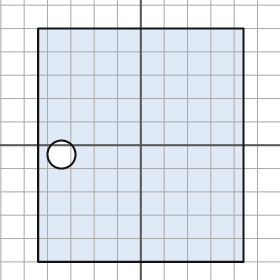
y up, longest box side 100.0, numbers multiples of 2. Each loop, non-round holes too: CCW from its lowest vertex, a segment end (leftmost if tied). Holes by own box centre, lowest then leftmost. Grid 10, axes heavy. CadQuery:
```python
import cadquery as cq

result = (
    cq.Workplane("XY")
    .moveTo(-44.0, -50.0)
    .lineTo(44.0, -50.0)
    .lineTo(44.0, 50.0)
    .lineTo(-44.0, 50.0)
    .close()
    .moveTo(-34.0, -4.0)
    .circle(6.0)
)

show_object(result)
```